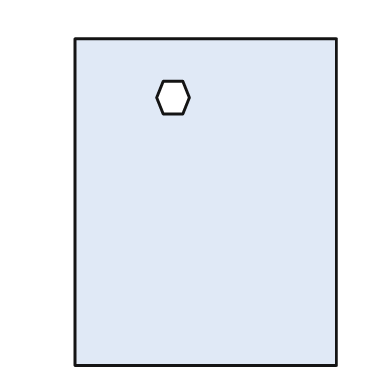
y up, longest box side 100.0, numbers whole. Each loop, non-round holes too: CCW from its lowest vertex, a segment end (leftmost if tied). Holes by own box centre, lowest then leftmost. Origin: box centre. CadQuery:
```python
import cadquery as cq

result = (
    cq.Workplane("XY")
    .moveTo(-40.0, -50.0)
    .lineTo(40.0, -50.0)
    .lineTo(40.0, 50.0)
    .lineTo(-40.0, 50.0)
    .close()
    .moveTo(-13.0, 27.0)
    .lineTo(-7.0, 27.0)
    .lineTo(-5.0, 32.0)
    .lineTo(-7.0, 37.0)
    .lineTo(-13.0, 37.0)
    .lineTo(-15.0, 32.0)
    .close()
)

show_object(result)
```